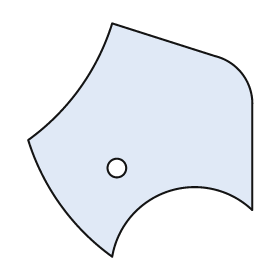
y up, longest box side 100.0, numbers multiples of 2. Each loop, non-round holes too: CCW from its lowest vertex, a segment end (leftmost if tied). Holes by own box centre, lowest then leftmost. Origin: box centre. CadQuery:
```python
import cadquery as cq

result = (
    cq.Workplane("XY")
    .moveTo(-12.0, -50.0)
    .threePointArc((12.0, -22.0), (48.0, -30.0))
    .lineTo(48.0, 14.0)
    .threePointArc((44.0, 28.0), (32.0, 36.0))
    .lineTo(-12.0, 50.0)
    .threePointArc((-26.0, 22.0), (-48.0, 0.0))
    .threePointArc((-34.0, -28.0), (-12.0, -50.0))
    .close()
    .moveTo(-10.0, -12.0)
    .circle(4.0)
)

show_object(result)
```